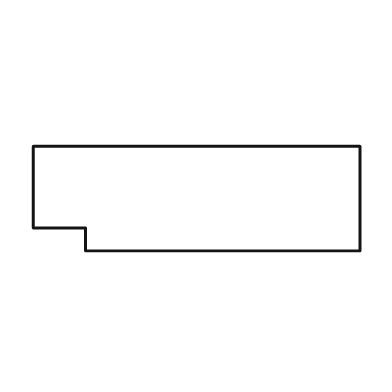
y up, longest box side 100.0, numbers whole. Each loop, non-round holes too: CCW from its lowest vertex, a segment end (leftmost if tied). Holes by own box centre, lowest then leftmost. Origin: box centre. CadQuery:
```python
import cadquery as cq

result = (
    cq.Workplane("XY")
    .moveTo(-34.0, -16.0)
    .lineTo(50.0, -16.0)
    .lineTo(50.0, 16.0)
    .lineTo(-50.0, 16.0)
    .lineTo(-50.0, -9.0)
    .lineTo(-34.0, -9.0)
    .close()
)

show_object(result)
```